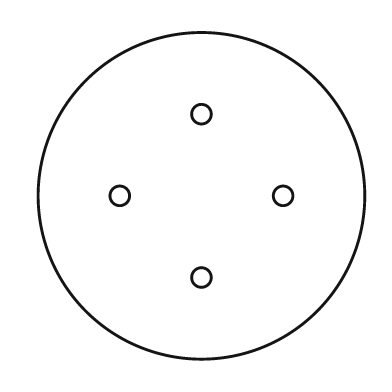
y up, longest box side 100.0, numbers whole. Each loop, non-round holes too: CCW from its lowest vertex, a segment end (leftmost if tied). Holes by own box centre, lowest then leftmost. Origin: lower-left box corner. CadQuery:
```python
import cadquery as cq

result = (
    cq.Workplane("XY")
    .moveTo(50.0, 50.0)
    .circle(50.0)
    .moveTo(50.0, 25.0)
    .circle(3.0)
    .moveTo(25.0, 50.0)
    .circle(3.0)
    .moveTo(75.0, 50.0)
    .circle(3.0)
    .moveTo(50.0, 75.0)
    .circle(3.0)
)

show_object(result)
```